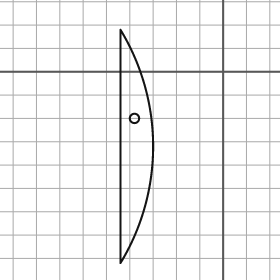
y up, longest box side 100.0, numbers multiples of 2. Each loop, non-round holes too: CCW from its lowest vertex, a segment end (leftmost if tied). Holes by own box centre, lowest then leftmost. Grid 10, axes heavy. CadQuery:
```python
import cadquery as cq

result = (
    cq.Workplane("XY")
    .moveTo(-44.0, -82.0)
    .threePointArc((-30.0, -32.0), (-44.0, 18.0))
    .close()
    .moveTo(-38.0, -20.0)
    .circle(2.0)
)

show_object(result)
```